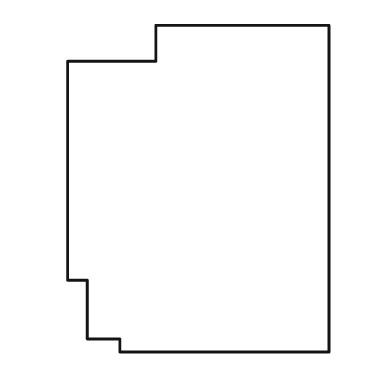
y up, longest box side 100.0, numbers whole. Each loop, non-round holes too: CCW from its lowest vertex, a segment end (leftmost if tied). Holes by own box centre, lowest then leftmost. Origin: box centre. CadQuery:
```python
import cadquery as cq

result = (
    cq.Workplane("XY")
    .moveTo(-24.0, -50.0)
    .lineTo(40.0, -50.0)
    .lineTo(40.0, 50.0)
    .lineTo(-13.0, 50.0)
    .lineTo(-13.0, 39.0)
    .lineTo(-40.0, 39.0)
    .lineTo(-40.0, -28.0)
    .lineTo(-34.0, -28.0)
    .lineTo(-34.0, -46.0)
    .lineTo(-24.0, -46.0)
    .close()
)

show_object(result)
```